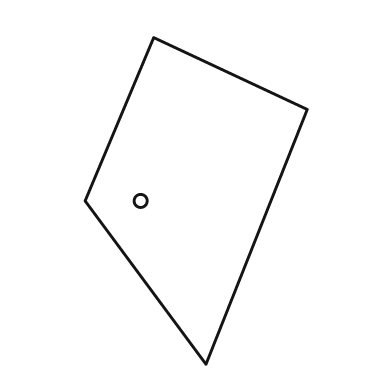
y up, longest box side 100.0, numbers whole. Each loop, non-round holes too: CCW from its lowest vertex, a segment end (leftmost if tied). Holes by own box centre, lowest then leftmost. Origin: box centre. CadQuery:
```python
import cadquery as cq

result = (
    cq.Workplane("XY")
    .moveTo(3.0, -50.0)
    .lineTo(34.0, 28.0)
    .lineTo(-13.0, 50.0)
    .lineTo(-34.0, 0.0)
    .close()
    .moveTo(-17.0, 0.0)
    .circle(2.0)
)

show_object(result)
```